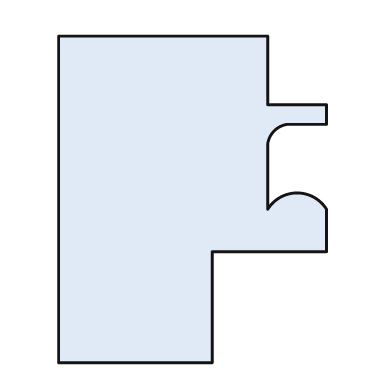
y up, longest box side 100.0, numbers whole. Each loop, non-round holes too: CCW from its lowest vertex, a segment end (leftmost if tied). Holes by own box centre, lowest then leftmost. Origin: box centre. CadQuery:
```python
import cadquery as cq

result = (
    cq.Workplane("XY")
    .moveTo(-41.0, -50.0)
    .lineTo(6.0, -50.0)
    .lineTo(6.0, -16.0)
    .lineTo(41.0, -16.0)
    .lineTo(41.0, -3.0)
    .threePointArc((32.0, 2.0), (23.0, -3.0))
    .lineTo(23.0, 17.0)
    .threePointArc((25.0, 21.0), (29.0, 23.0))
    .lineTo(41.0, 23.0)
    .lineTo(41.0, 29.0)
    .lineTo(23.0, 29.0)
    .lineTo(23.0, 50.0)
    .lineTo(-41.0, 50.0)
    .close()
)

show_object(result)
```